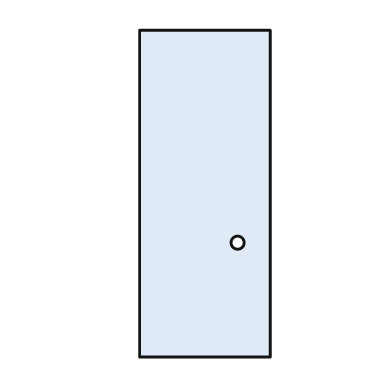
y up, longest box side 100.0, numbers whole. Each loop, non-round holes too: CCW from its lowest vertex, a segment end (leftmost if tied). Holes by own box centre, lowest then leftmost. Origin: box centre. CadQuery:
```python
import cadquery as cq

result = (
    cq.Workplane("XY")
    .moveTo(-20.0, -50.0)
    .lineTo(20.0, -50.0)
    .lineTo(20.0, 50.0)
    .lineTo(-20.0, 50.0)
    .close()
    .moveTo(10.0, -15.0)
    .circle(2.0)
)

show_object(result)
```